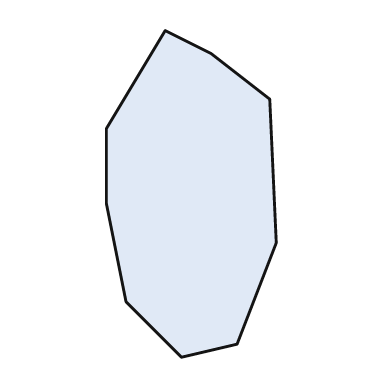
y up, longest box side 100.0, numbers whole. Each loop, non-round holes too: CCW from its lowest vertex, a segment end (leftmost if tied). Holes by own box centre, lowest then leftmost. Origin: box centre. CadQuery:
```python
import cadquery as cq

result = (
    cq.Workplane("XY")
    .moveTo(-3.0, -50.0)
    .lineTo(14.0, -46.0)
    .lineTo(26.0, -15.0)
    .lineTo(24.0, 29.0)
    .lineTo(6.0, 43.0)
    .lineTo(-8.0, 50.0)
    .lineTo(-26.0, 20.0)
    .lineTo(-26.0, -3.0)
    .lineTo(-20.0, -33.0)
    .close()
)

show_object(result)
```